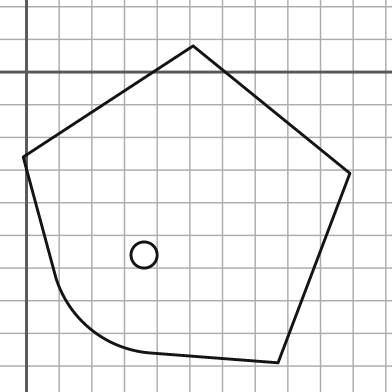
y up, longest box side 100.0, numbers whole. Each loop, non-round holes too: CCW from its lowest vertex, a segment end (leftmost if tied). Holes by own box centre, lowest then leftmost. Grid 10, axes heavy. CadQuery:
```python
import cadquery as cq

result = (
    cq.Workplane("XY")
    .moveTo(77.0, -89.0)
    .lineTo(99.0, -31.0)
    .lineTo(51.0, 8.0)
    .lineTo(-1.0, -26.0)
    .lineTo(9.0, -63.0)
    .threePointArc((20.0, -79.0), (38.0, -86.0))
    .close()
    .moveTo(36.0, -56.0)
    .circle(4.0)
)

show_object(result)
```